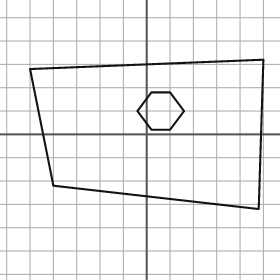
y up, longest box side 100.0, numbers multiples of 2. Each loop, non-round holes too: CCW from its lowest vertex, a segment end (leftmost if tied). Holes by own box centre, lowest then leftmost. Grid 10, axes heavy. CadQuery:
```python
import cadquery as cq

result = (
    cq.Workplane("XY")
    .moveTo(48.0, -32.0)
    .lineTo(50.0, 32.0)
    .lineTo(-50.0, 28.0)
    .lineTo(-40.0, -22.0)
    .close()
    .moveTo(2.0, 2.0)
    .lineTo(10.0, 2.0)
    .lineTo(16.0, 10.0)
    .lineTo(10.0, 18.0)
    .lineTo(2.0, 18.0)
    .lineTo(-4.0, 10.0)
    .close()
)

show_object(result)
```